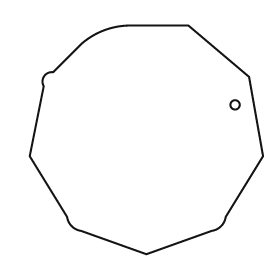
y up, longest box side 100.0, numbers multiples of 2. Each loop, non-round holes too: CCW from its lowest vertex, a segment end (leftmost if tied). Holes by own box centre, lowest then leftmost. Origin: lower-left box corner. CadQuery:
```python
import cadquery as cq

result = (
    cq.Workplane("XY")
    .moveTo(50.0, 0.0)
    .lineTo(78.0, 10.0)
    .threePointArc((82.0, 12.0), (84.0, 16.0))
    .lineTo(100.0, 42.0)
    .lineTo(94.0, 76.0)
    .lineTo(68.0, 98.0)
    .lineTo(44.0, 98.0)
    .threePointArc((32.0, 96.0), (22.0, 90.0))
    .lineTo(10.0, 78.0)
    .threePointArc((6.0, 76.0), (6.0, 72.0))
    .lineTo(0.0, 42.0)
    .lineTo(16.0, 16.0)
    .threePointArc((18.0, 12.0), (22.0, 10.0))
    .close()
    .moveTo(88.0, 64.0)
    .circle(2.0)
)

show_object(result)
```